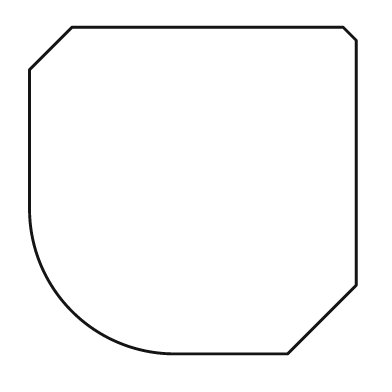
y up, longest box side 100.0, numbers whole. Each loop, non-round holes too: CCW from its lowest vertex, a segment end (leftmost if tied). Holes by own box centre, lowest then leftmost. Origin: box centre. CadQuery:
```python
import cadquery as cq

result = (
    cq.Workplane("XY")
    .moveTo(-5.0, -50.0)
    .lineTo(29.0, -50.0)
    .lineTo(50.0, -29.0)
    .lineTo(50.0, 46.0)
    .lineTo(46.0, 50.0)
    .lineTo(-37.0, 50.0)
    .lineTo(-50.0, 37.0)
    .lineTo(-50.0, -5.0)
    .threePointArc((-37.0, -37.0), (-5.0, -50.0))
    .close()
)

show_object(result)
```